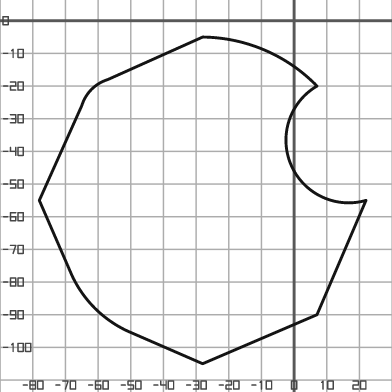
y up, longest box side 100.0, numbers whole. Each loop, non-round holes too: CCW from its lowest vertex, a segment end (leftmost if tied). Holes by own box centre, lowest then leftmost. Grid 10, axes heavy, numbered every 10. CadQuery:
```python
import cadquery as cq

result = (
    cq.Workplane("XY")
    .moveTo(-28.0, -105.0)
    .lineTo(7.0, -90.0)
    .lineTo(22.0, -55.0)
    .threePointArc((-1.0, -44.0), (7.0, -20.0))
    .threePointArc((-9.0, -9.0), (-28.0, -5.0))
    .lineTo(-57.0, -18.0)
    .threePointArc((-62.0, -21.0), (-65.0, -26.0))
    .lineTo(-78.0, -55.0)
    .lineTo(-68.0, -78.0)
    .threePointArc((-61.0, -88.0), (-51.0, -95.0))
    .close()
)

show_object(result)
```